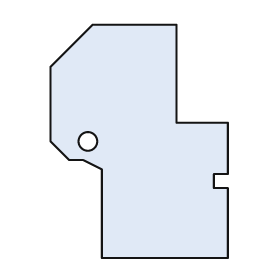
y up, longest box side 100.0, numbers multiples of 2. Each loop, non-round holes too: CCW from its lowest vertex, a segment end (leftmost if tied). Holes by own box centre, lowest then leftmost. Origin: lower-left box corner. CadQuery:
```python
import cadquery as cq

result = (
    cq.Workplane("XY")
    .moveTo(22.0, 0.0)
    .lineTo(76.0, 0.0)
    .lineTo(76.0, 30.0)
    .lineTo(70.0, 30.0)
    .lineTo(70.0, 36.0)
    .lineTo(76.0, 36.0)
    .lineTo(76.0, 58.0)
    .lineTo(54.0, 58.0)
    .lineTo(54.0, 100.0)
    .lineTo(18.0, 100.0)
    .lineTo(0.0, 82.0)
    .lineTo(0.0, 50.0)
    .lineTo(8.0, 42.0)
    .lineTo(14.0, 42.0)
    .lineTo(22.0, 38.0)
    .close()
    .moveTo(16.0, 50.0)
    .circle(4.0)
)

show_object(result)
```